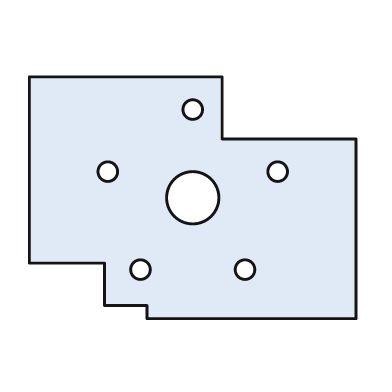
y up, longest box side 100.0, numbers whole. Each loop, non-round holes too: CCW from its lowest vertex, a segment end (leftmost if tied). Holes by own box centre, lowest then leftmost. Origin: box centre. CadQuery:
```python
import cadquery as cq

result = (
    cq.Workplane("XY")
    .moveTo(-14.0, -37.0)
    .lineTo(50.0, -37.0)
    .lineTo(50.0, 18.0)
    .lineTo(9.0, 18.0)
    .lineTo(9.0, 37.0)
    .lineTo(-50.0, 37.0)
    .lineTo(-50.0, -20.0)
    .lineTo(-27.0, -20.0)
    .lineTo(-27.0, -33.0)
    .lineTo(-14.0, -33.0)
    .close()
    .moveTo(-16.0, -22.0)
    .circle(3.0)
    .moveTo(16.0, -22.0)
    .circle(3.0)
    .moveTo(0.0, 0.0)
    .circle(8.0)
    .moveTo(-26.0, 8.0)
    .circle(3.0)
    .moveTo(26.0, 8.0)
    .circle(3.0)
    .moveTo(0.0, 27.0)
    .circle(3.0)
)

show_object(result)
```